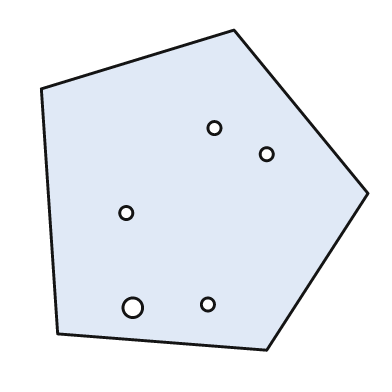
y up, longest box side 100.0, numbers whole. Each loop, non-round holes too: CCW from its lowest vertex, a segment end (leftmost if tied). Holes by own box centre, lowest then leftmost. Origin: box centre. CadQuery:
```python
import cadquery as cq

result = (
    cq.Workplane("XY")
    .moveTo(19.0, -49.0)
    .lineTo(50.0, -1.0)
    .lineTo(9.0, 49.0)
    .lineTo(-50.0, 31.0)
    .lineTo(-45.0, -44.0)
    .close()
    .moveTo(-22.0, -36.0)
    .circle(3.0)
    .moveTo(1.0, -35.0)
    .circle(2.0)
    .moveTo(-24.0, -7.0)
    .circle(2.0)
    .moveTo(19.0, 11.0)
    .circle(2.0)
    .moveTo(3.0, 19.0)
    .circle(2.0)
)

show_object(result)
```